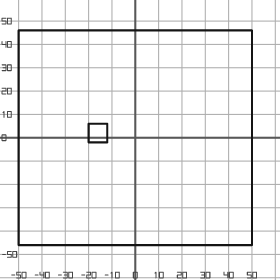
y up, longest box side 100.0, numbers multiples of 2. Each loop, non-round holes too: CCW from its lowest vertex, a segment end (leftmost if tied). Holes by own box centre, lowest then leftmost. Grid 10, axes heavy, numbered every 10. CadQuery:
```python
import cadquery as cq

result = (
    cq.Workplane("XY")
    .moveTo(-50.0, -46.0)
    .lineTo(50.0, -46.0)
    .lineTo(50.0, 46.0)
    .lineTo(-50.0, 46.0)
    .close()
    .moveTo(-20.0, -2.0)
    .lineTo(-12.0, -2.0)
    .lineTo(-12.0, 6.0)
    .lineTo(-20.0, 6.0)
    .close()
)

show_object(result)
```